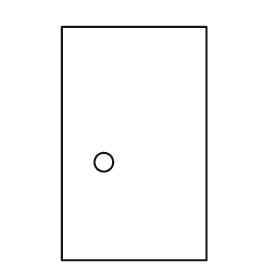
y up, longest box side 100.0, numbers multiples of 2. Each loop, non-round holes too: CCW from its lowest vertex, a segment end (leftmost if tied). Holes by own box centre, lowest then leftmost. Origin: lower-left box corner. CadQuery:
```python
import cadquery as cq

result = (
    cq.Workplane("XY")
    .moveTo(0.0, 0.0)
    .lineTo(62.0, 0.0)
    .lineTo(62.0, 100.0)
    .lineTo(0.0, 100.0)
    .close()
    .moveTo(18.0, 42.0)
    .circle(4.0)
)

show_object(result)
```